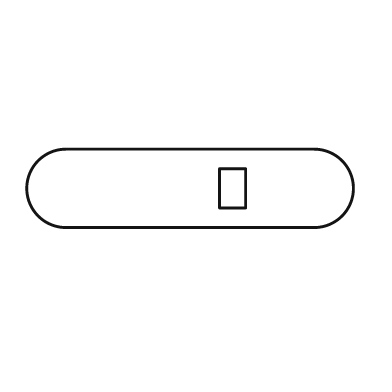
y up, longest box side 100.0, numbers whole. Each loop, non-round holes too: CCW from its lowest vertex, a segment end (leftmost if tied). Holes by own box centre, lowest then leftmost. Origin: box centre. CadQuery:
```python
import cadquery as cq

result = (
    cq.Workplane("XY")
    .moveTo(-38.0, -12.0)
    .lineTo(38.0, -12.0)
    .threePointArc((50.0, 0.0), (38.0, 12.0))
    .lineTo(-38.0, 12.0)
    .threePointArc((-50.0, 0.0), (-38.0, -12.0))
    .close()
    .moveTo(9.0, -6.0)
    .lineTo(17.0, -6.0)
    .lineTo(17.0, 6.0)
    .lineTo(9.0, 6.0)
    .close()
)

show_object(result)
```